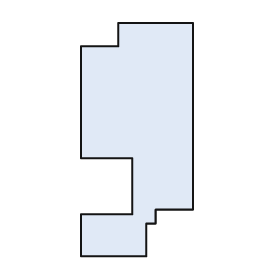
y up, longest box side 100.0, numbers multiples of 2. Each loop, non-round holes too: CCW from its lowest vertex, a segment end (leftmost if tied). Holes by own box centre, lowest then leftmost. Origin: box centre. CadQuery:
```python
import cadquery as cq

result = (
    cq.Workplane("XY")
    .moveTo(-24.0, -50.0)
    .lineTo(4.0, -50.0)
    .lineTo(4.0, -36.0)
    .lineTo(8.0, -36.0)
    .lineTo(8.0, -30.0)
    .lineTo(24.0, -30.0)
    .lineTo(24.0, 50.0)
    .lineTo(-8.0, 50.0)
    .lineTo(-8.0, 40.0)
    .lineTo(-24.0, 40.0)
    .lineTo(-24.0, -8.0)
    .lineTo(-2.0, -8.0)
    .lineTo(-2.0, -32.0)
    .lineTo(-24.0, -32.0)
    .close()
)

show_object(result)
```